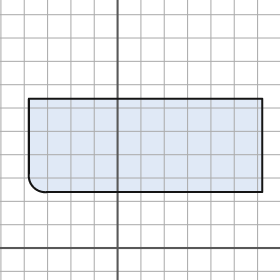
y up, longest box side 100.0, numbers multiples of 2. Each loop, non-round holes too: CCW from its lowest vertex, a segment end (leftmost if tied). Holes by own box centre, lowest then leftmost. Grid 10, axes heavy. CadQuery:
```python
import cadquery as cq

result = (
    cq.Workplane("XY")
    .moveTo(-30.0, 24.0)
    .lineTo(62.0, 24.0)
    .lineTo(62.0, 64.0)
    .lineTo(-38.0, 64.0)
    .lineTo(-38.0, 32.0)
    .threePointArc((-36.0, 26.0), (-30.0, 24.0))
    .close()
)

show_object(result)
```